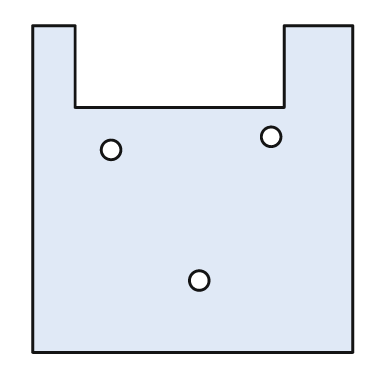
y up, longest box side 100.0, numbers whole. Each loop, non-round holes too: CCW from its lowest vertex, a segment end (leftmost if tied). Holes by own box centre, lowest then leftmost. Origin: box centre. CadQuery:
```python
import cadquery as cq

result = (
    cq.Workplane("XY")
    .moveTo(-49.0, -50.0)
    .lineTo(49.0, -50.0)
    .lineTo(49.0, 50.0)
    .lineTo(28.0, 50.0)
    .lineTo(28.0, 25.0)
    .lineTo(-36.0, 25.0)
    .lineTo(-36.0, 50.0)
    .lineTo(-49.0, 50.0)
    .close()
    .moveTo(2.0, -28.0)
    .circle(3.0)
    .moveTo(-25.0, 12.0)
    .circle(3.0)
    .moveTo(24.0, 16.0)
    .circle(3.0)
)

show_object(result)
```